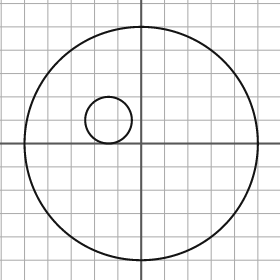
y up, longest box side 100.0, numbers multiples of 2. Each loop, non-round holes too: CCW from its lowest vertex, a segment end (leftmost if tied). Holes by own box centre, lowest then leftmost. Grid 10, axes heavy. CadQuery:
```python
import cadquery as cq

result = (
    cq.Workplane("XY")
    .moveTo(0.0, 0.0)
    .circle(50.0)
    .moveTo(-14.0, 10.0)
    .circle(10.0)
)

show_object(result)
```